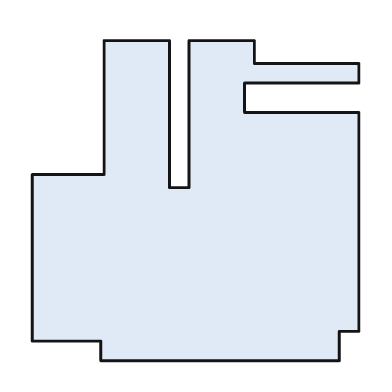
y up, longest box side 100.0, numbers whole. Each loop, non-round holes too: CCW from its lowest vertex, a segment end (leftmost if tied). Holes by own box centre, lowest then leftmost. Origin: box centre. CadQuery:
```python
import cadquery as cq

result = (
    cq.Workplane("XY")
    .moveTo(-29.0, -49.0)
    .lineTo(44.0, -49.0)
    .lineTo(44.0, -40.0)
    .lineTo(50.0, -40.0)
    .lineTo(50.0, 27.0)
    .lineTo(15.0, 27.0)
    .lineTo(15.0, 36.0)
    .lineTo(50.0, 36.0)
    .lineTo(50.0, 42.0)
    .lineTo(18.0, 42.0)
    .lineTo(18.0, 49.0)
    .lineTo(-2.0, 49.0)
    .lineTo(-2.0, 4.0)
    .lineTo(-8.0, 4.0)
    .lineTo(-8.0, 49.0)
    .lineTo(-28.0, 49.0)
    .lineTo(-28.0, 8.0)
    .lineTo(-50.0, 8.0)
    .lineTo(-50.0, -43.0)
    .lineTo(-29.0, -43.0)
    .close()
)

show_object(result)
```